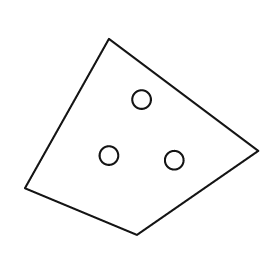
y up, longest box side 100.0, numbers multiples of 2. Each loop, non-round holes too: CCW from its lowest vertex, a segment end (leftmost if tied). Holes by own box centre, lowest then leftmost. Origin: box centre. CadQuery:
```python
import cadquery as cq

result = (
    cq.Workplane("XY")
    .moveTo(-2.0, -42.0)
    .lineTo(50.0, -6.0)
    .lineTo(-14.0, 42.0)
    .lineTo(-50.0, -22.0)
    .close()
    .moveTo(14.0, -10.0)
    .circle(4.0)
    .moveTo(-14.0, -8.0)
    .circle(4.0)
    .moveTo(0.0, 16.0)
    .circle(4.0)
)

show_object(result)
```